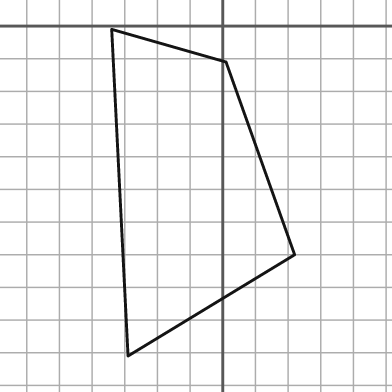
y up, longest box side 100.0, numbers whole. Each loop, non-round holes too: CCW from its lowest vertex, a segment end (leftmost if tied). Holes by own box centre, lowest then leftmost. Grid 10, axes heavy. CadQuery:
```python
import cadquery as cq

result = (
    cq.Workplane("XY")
    .moveTo(-29.0, -101.0)
    .lineTo(22.0, -70.0)
    .lineTo(1.0, -11.0)
    .lineTo(-34.0, -1.0)
    .close()
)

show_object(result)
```